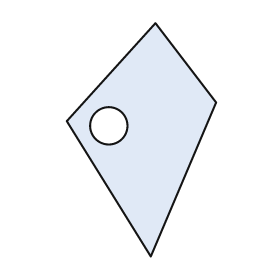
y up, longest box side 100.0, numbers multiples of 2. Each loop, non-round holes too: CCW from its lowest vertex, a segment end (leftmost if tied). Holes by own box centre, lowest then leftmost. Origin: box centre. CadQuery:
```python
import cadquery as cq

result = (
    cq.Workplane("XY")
    .moveTo(4.0, -50.0)
    .lineTo(32.0, 16.0)
    .lineTo(6.0, 50.0)
    .lineTo(-32.0, 8.0)
    .close()
    .moveTo(-14.0, 6.0)
    .circle(8.0)
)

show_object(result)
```